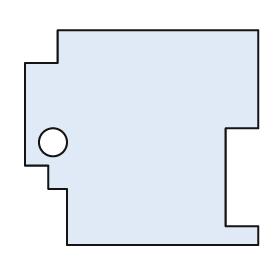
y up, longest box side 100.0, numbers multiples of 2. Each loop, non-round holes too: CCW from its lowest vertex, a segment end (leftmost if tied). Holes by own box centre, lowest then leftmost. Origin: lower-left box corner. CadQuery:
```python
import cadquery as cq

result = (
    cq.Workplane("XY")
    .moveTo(18.0, 0.0)
    .lineTo(100.0, 0.0)
    .lineTo(100.0, 8.0)
    .lineTo(86.0, 8.0)
    .lineTo(86.0, 50.0)
    .lineTo(100.0, 50.0)
    .lineTo(100.0, 92.0)
    .lineTo(14.0, 92.0)
    .lineTo(14.0, 78.0)
    .lineTo(0.0, 78.0)
    .lineTo(0.0, 34.0)
    .lineTo(10.0, 34.0)
    .lineTo(10.0, 24.0)
    .lineTo(18.0, 24.0)
    .close()
    .moveTo(12.0, 44.0)
    .circle(6.0)
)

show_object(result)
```